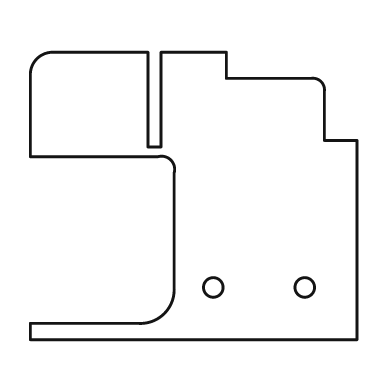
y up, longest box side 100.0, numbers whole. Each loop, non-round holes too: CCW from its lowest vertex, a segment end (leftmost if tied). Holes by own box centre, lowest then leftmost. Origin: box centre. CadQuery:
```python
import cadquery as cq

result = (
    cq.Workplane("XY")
    .moveTo(-50.0, -44.0)
    .lineTo(50.0, -44.0)
    .lineTo(50.0, 17.0)
    .lineTo(40.0, 17.0)
    .lineTo(40.0, 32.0)
    .threePointArc((39.0, 35.0), (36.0, 36.0))
    .lineTo(10.0, 36.0)
    .lineTo(10.0, 44.0)
    .lineTo(-10.0, 44.0)
    .lineTo(-10.0, 15.0)
    .lineTo(-14.0, 15.0)
    .lineTo(-14.0, 44.0)
    .lineTo(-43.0, 44.0)
    .threePointArc((-48.0, 42.0), (-50.0, 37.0))
    .lineTo(-50.0, 12.0)
    .lineTo(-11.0, 12.0)
    .threePointArc((-7.0, 11.0), (-6.0, 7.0))
    .lineTo(-6.0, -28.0)
    .threePointArc((-9.0, -36.0), (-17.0, -39.0))
    .lineTo(-50.0, -39.0)
    .close()
    .moveTo(6.0, -28.0)
    .circle(3.0)
    .moveTo(34.0, -28.0)
    .circle(3.0)
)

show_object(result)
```